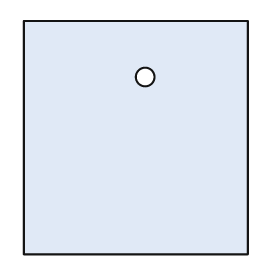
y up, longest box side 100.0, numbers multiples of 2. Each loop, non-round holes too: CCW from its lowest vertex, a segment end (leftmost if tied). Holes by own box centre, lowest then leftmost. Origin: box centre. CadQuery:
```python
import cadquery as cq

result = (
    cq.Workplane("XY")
    .moveTo(-48.0, -50.0)
    .lineTo(48.0, -50.0)
    .lineTo(48.0, 50.0)
    .lineTo(-48.0, 50.0)
    .close()
    .moveTo(4.0, 26.0)
    .circle(4.0)
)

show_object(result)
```